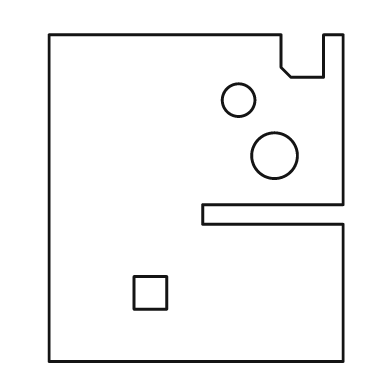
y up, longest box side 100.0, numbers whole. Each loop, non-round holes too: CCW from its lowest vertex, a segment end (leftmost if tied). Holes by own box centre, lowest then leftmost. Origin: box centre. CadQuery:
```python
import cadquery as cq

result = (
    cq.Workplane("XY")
    .moveTo(-45.0, -50.0)
    .lineTo(45.0, -50.0)
    .lineTo(45.0, -8.0)
    .lineTo(2.0, -8.0)
    .lineTo(2.0, -2.0)
    .lineTo(45.0, -2.0)
    .lineTo(45.0, 50.0)
    .lineTo(39.0, 50.0)
    .lineTo(39.0, 37.0)
    .lineTo(29.0, 37.0)
    .lineTo(26.0, 40.0)
    .lineTo(26.0, 50.0)
    .lineTo(-45.0, 50.0)
    .close()
    .moveTo(-19.0, -34.0)
    .lineTo(-9.0, -34.0)
    .lineTo(-9.0, -24.0)
    .lineTo(-19.0, -24.0)
    .close()
    .moveTo(24.0, 13.0)
    .circle(7.0)
    .moveTo(13.0, 30.0)
    .circle(5.0)
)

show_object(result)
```